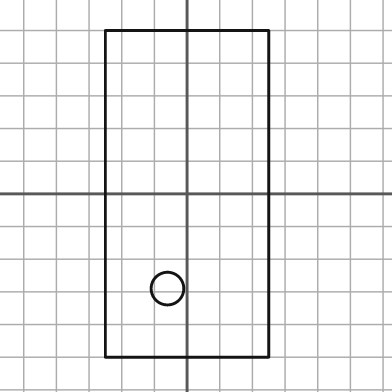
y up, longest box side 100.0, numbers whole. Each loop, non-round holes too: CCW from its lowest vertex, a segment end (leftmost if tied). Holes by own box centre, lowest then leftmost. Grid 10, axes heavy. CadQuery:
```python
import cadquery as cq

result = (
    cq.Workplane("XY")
    .moveTo(-25.0, -50.0)
    .lineTo(25.0, -50.0)
    .lineTo(25.0, 50.0)
    .lineTo(-25.0, 50.0)
    .close()
    .moveTo(-6.0, -29.0)
    .circle(5.0)
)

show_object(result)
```